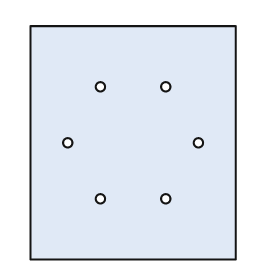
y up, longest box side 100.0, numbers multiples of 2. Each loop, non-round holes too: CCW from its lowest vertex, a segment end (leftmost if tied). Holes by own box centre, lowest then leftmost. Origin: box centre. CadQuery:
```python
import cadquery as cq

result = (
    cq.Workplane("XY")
    .moveTo(-44.0, -50.0)
    .lineTo(44.0, -50.0)
    .lineTo(44.0, 50.0)
    .lineTo(-44.0, 50.0)
    .close()
    .moveTo(-14.0, -24.0)
    .circle(2.0)
    .moveTo(14.0, -24.0)
    .circle(2.0)
    .moveTo(-28.0, 0.0)
    .circle(2.0)
    .moveTo(28.0, 0.0)
    .circle(2.0)
    .moveTo(-14.0, 24.0)
    .circle(2.0)
    .moveTo(14.0, 24.0)
    .circle(2.0)
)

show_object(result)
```